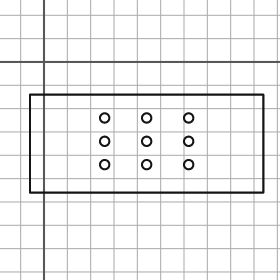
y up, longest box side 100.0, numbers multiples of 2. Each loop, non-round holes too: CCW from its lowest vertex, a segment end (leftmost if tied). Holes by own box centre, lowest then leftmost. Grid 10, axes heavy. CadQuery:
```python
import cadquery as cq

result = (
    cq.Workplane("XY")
    .moveTo(-6.0, -56.0)
    .lineTo(94.0, -56.0)
    .lineTo(94.0, -14.0)
    .lineTo(-6.0, -14.0)
    .close()
    .moveTo(26.0, -44.0)
    .circle(2.0)
    .moveTo(44.0, -44.0)
    .circle(2.0)
    .moveTo(62.0, -44.0)
    .circle(2.0)
    .moveTo(26.0, -34.0)
    .circle(2.0)
    .moveTo(44.0, -34.0)
    .circle(2.0)
    .moveTo(62.0, -34.0)
    .circle(2.0)
    .moveTo(26.0, -24.0)
    .circle(2.0)
    .moveTo(44.0, -24.0)
    .circle(2.0)
    .moveTo(62.0, -24.0)
    .circle(2.0)
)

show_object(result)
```